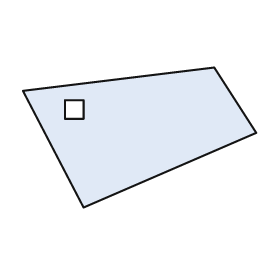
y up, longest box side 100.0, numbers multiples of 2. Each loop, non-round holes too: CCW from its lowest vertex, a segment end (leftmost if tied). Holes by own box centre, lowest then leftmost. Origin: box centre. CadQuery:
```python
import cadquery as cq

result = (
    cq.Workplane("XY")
    .moveTo(-24.0, -30.0)
    .lineTo(50.0, 2.0)
    .lineTo(32.0, 30.0)
    .lineTo(-50.0, 20.0)
    .close()
    .moveTo(-32.0, 8.0)
    .lineTo(-24.0, 8.0)
    .lineTo(-24.0, 16.0)
    .lineTo(-32.0, 16.0)
    .close()
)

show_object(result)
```